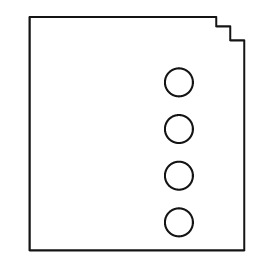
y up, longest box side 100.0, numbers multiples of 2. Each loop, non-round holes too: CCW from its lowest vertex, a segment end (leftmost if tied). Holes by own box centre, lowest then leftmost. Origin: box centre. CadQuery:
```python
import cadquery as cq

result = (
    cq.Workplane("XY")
    .moveTo(-46.0, -50.0)
    .lineTo(46.0, -50.0)
    .lineTo(46.0, 40.0)
    .lineTo(40.0, 40.0)
    .lineTo(40.0, 46.0)
    .lineTo(34.0, 46.0)
    .lineTo(34.0, 50.0)
    .lineTo(-46.0, 50.0)
    .close()
    .moveTo(18.0, -38.0)
    .circle(6.0)
    .moveTo(18.0, -18.0)
    .circle(6.0)
    .moveTo(18.0, 2.0)
    .circle(6.0)
    .moveTo(18.0, 22.0)
    .circle(6.0)
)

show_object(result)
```